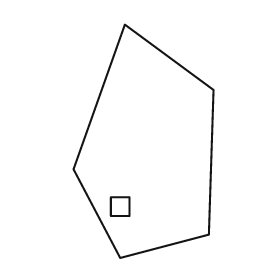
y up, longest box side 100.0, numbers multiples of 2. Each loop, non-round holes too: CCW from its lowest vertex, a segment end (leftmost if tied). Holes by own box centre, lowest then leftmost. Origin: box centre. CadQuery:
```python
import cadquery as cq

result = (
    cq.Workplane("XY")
    .moveTo(-10.0, -50.0)
    .lineTo(28.0, -40.0)
    .lineTo(30.0, 22.0)
    .lineTo(-8.0, 50.0)
    .lineTo(-30.0, -12.0)
    .close()
    .moveTo(-14.0, -32.0)
    .lineTo(-6.0, -32.0)
    .lineTo(-6.0, -24.0)
    .lineTo(-14.0, -24.0)
    .close()
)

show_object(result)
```